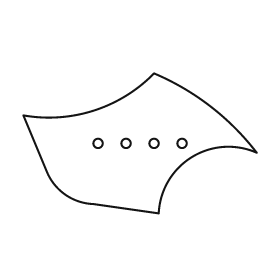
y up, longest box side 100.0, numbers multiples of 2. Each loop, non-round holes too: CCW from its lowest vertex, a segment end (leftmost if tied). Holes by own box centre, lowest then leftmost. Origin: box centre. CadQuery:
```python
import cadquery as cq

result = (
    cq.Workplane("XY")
    .moveTo(8.0, -30.0)
    .threePointArc((22.0, -6.0), (50.0, -4.0))
    .threePointArc((30.0, 16.0), (6.0, 30.0))
    .threePointArc((-20.0, 14.0), (-50.0, 12.0))
    .lineTo(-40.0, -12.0)
    .threePointArc((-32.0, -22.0), (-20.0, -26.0))
    .close()
    .moveTo(-18.0, 0.0)
    .circle(2.0)
    .moveTo(-6.0, 0.0)
    .circle(2.0)
    .moveTo(6.0, 0.0)
    .circle(2.0)
    .moveTo(18.0, 0.0)
    .circle(2.0)
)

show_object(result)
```